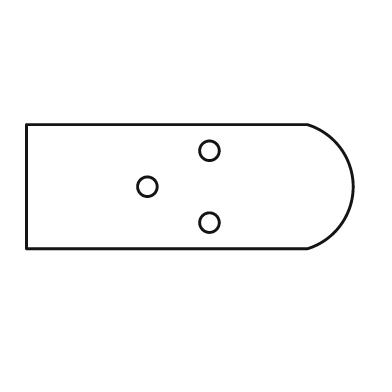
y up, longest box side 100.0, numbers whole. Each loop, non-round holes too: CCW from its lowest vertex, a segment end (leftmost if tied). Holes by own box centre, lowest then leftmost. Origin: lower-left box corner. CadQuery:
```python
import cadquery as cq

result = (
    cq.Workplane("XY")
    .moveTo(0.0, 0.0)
    .lineTo(86.0, 0.0)
    .threePointArc((100.0, 19.0), (86.0, 38.0))
    .lineTo(0.0, 38.0)
    .close()
    .moveTo(56.0, 8.0)
    .circle(3.0)
    .moveTo(37.0, 19.0)
    .circle(3.0)
    .moveTo(56.0, 30.0)
    .circle(3.0)
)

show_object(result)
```